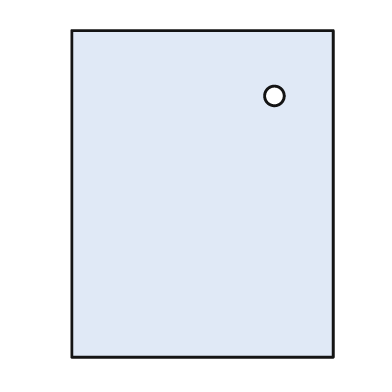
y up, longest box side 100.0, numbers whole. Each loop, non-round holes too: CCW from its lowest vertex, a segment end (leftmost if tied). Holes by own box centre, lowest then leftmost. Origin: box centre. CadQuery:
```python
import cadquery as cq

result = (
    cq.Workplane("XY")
    .moveTo(-40.0, -50.0)
    .lineTo(40.0, -50.0)
    .lineTo(40.0, 50.0)
    .lineTo(-40.0, 50.0)
    .close()
    .moveTo(22.0, 30.0)
    .circle(3.0)
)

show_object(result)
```